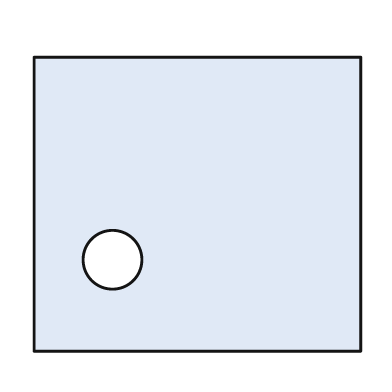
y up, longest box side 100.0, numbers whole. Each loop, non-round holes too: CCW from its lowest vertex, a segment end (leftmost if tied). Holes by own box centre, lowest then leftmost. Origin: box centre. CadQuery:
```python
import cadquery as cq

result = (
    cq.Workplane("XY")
    .moveTo(-50.0, -45.0)
    .lineTo(50.0, -45.0)
    .lineTo(50.0, 45.0)
    .lineTo(-50.0, 45.0)
    .close()
    .moveTo(-26.0, -17.0)
    .circle(9.0)
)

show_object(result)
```